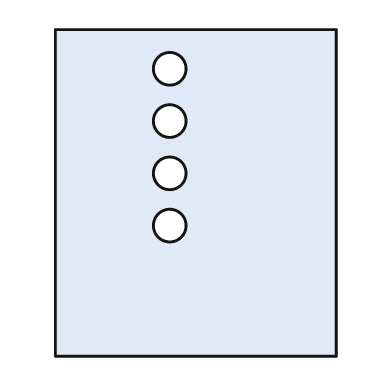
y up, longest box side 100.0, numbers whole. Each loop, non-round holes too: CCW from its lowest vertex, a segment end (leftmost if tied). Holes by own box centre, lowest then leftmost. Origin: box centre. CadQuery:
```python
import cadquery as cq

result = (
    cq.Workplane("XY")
    .moveTo(-43.0, -50.0)
    .lineTo(43.0, -50.0)
    .lineTo(43.0, 50.0)
    .lineTo(-43.0, 50.0)
    .close()
    .moveTo(-8.0, -10.0)
    .circle(5.0)
    .moveTo(-8.0, 6.0)
    .circle(5.0)
    .moveTo(-8.0, 22.0)
    .circle(5.0)
    .moveTo(-8.0, 38.0)
    .circle(5.0)
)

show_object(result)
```